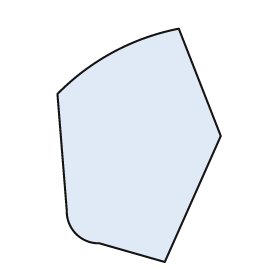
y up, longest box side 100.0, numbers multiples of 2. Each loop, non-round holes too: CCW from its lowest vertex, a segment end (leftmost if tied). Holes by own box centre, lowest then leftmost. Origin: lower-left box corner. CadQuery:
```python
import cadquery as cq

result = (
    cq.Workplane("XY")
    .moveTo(46.0, 0.0)
    .lineTo(70.0, 54.0)
    .lineTo(52.0, 100.0)
    .threePointArc((24.0, 90.0), (0.0, 72.0))
    .lineTo(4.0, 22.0)
    .threePointArc((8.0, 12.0), (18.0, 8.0))
    .close()
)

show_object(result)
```